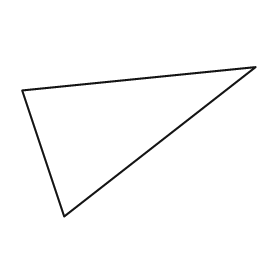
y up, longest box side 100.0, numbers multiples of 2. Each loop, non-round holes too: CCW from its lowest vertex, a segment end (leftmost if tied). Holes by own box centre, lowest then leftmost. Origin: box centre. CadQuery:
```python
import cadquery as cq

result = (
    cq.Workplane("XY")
    .moveTo(-32.0, -32.0)
    .lineTo(50.0, 32.0)
    .lineTo(-50.0, 22.0)
    .close()
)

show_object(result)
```